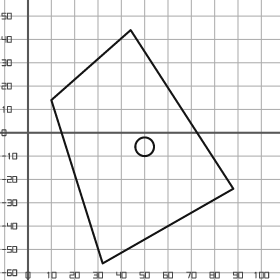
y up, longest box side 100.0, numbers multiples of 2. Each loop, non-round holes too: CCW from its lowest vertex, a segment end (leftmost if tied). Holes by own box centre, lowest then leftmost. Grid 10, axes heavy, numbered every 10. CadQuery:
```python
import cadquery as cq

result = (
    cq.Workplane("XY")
    .moveTo(32.0, -56.0)
    .lineTo(88.0, -24.0)
    .lineTo(44.0, 44.0)
    .lineTo(10.0, 14.0)
    .close()
    .moveTo(50.0, -6.0)
    .circle(4.0)
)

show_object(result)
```